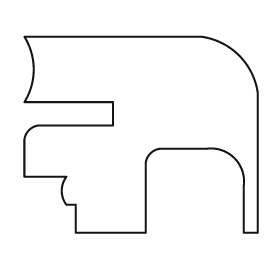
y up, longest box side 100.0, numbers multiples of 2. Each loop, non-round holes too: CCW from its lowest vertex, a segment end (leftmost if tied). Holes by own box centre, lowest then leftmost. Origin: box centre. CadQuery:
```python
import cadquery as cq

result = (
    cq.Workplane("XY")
    .moveTo(-28.0, -42.0)
    .lineTo(2.0, -42.0)
    .lineTo(2.0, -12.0)
    .threePointArc((4.0, -8.0), (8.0, -6.0))
    .lineTo(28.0, -6.0)
    .threePointArc((40.0, -10.0), (44.0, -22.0))
    .lineTo(44.0, -42.0)
    .lineTo(50.0, -42.0)
    .lineTo(50.0, 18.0)
    .threePointArc((42.0, 34.0), (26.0, 42.0))
    .lineTo(-50.0, 42.0)
    .threePointArc((-46.0, 28.0), (-50.0, 14.0))
    .lineTo(-12.0, 14.0)
    .lineTo(-12.0, 4.0)
    .lineTo(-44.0, 4.0)
    .threePointArc((-48.0, 2.0), (-50.0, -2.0))
    .lineTo(-50.0, -18.0)
    .lineTo(-32.0, -18.0)
    .threePointArc((-34.0, -24.0), (-32.0, -30.0))
    .lineTo(-28.0, -30.0)
    .close()
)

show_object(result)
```